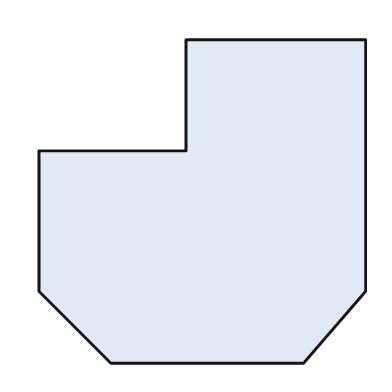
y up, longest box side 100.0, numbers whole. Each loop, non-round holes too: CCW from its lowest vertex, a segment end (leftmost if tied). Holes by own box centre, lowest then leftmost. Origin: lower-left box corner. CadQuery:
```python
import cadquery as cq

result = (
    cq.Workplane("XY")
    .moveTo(22.0, 0.0)
    .lineTo(81.0, 0.0)
    .lineTo(100.0, 22.0)
    .lineTo(100.0, 99.0)
    .lineTo(45.0, 99.0)
    .lineTo(45.0, 65.0)
    .lineTo(0.0, 65.0)
    .lineTo(0.0, 22.0)
    .close()
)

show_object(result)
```